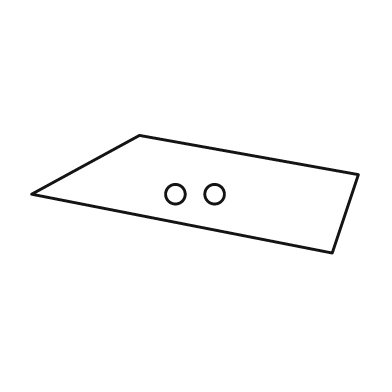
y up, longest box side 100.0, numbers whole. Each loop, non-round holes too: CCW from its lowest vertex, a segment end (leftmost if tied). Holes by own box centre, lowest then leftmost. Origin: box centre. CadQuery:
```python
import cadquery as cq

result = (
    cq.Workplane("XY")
    .moveTo(42.0, -18.0)
    .lineTo(50.0, 6.0)
    .lineTo(-17.0, 18.0)
    .lineTo(-50.0, 0.0)
    .close()
    .moveTo(-6.0, 0.0)
    .circle(3.0)
    .moveTo(6.0, 0.0)
    .circle(3.0)
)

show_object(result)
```